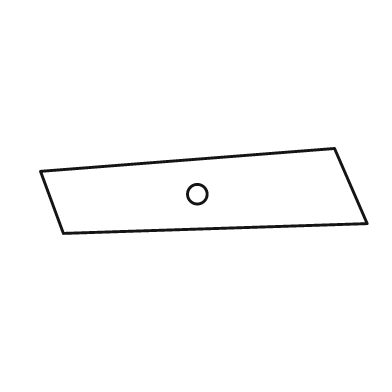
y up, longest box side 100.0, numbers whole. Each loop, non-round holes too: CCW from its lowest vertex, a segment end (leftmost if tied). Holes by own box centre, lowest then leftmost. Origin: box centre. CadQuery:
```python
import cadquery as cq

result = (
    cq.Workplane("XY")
    .moveTo(-43.0, -13.0)
    .lineTo(50.0, -10.0)
    .lineTo(40.0, 13.0)
    .lineTo(-50.0, 6.0)
    .close()
    .moveTo(-2.0, -1.0)
    .circle(3.0)
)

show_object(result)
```